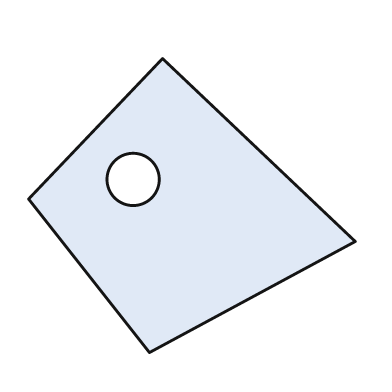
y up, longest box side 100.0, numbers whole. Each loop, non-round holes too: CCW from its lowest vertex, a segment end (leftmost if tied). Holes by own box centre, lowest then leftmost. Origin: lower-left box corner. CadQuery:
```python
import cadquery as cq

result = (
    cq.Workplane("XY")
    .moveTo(37.0, 0.0)
    .lineTo(100.0, 34.0)
    .lineTo(41.0, 90.0)
    .lineTo(0.0, 47.0)
    .close()
    .moveTo(32.0, 53.0)
    .circle(8.0)
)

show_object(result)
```